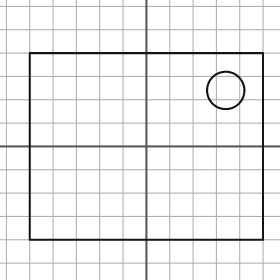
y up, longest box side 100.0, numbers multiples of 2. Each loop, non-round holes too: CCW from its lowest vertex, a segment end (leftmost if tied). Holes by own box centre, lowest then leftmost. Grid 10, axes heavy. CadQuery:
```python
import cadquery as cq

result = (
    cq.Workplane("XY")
    .moveTo(-50.0, -40.0)
    .lineTo(50.0, -40.0)
    .lineTo(50.0, 40.0)
    .lineTo(-50.0, 40.0)
    .close()
    .moveTo(34.0, 24.0)
    .circle(8.0)
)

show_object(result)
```